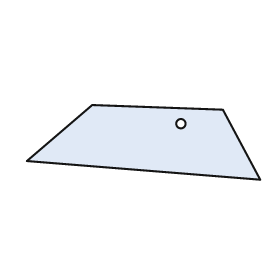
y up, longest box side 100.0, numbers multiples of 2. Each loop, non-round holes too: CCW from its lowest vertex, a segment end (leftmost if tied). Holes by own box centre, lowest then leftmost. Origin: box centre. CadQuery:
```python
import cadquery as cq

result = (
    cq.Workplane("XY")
    .moveTo(50.0, -16.0)
    .lineTo(34.0, 14.0)
    .lineTo(-22.0, 16.0)
    .lineTo(-50.0, -8.0)
    .close()
    .moveTo(16.0, 8.0)
    .circle(2.0)
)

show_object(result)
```